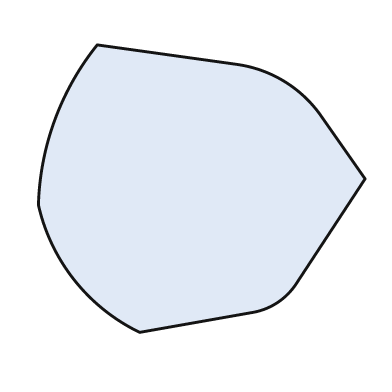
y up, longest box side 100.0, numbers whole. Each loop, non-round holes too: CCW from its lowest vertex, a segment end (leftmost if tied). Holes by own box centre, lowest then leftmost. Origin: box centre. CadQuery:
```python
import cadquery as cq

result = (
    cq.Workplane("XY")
    .moveTo(-19.0, -44.0)
    .lineTo(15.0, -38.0)
    .threePointArc((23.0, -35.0), (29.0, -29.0))
    .lineTo(50.0, 3.0)
    .lineTo(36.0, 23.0)
    .threePointArc((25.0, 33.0), (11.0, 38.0))
    .lineTo(-32.0, 44.0)
    .threePointArc((-45.0, 21.0), (-50.0, -5.0))
    .threePointArc((-39.0, -28.0), (-19.0, -44.0))
    .close()
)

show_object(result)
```